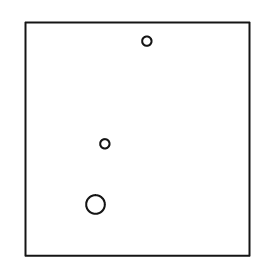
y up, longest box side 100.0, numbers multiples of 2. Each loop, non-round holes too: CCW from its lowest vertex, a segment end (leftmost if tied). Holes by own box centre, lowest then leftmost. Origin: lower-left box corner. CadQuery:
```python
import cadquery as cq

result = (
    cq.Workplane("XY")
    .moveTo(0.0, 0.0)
    .lineTo(96.0, 0.0)
    .lineTo(96.0, 100.0)
    .lineTo(0.0, 100.0)
    .close()
    .moveTo(30.0, 22.0)
    .circle(4.0)
    .moveTo(34.0, 48.0)
    .circle(2.0)
    .moveTo(52.0, 92.0)
    .circle(2.0)
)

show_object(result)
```